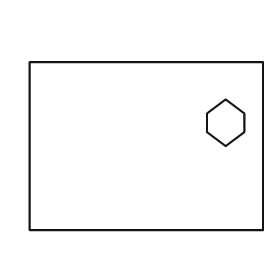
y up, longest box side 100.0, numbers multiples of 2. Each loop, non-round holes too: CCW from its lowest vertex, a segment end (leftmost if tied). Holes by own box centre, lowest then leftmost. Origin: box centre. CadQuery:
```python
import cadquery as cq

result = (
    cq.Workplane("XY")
    .moveTo(-50.0, -36.0)
    .lineTo(50.0, -36.0)
    .lineTo(50.0, 36.0)
    .lineTo(-50.0, 36.0)
    .close()
    .moveTo(34.0, 0.0)
    .lineTo(42.0, 6.0)
    .lineTo(42.0, 14.0)
    .lineTo(34.0, 20.0)
    .lineTo(26.0, 14.0)
    .lineTo(26.0, 6.0)
    .close()
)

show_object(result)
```